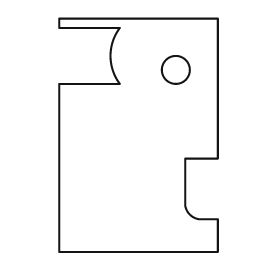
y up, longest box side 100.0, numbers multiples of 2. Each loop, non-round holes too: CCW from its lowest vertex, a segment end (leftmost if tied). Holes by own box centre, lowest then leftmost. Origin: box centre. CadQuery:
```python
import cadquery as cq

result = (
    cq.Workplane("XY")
    .moveTo(-34.0, -50.0)
    .lineTo(34.0, -50.0)
    .lineTo(34.0, -36.0)
    .lineTo(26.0, -36.0)
    .threePointArc((22.0, -34.0), (20.0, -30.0))
    .lineTo(20.0, -10.0)
    .lineTo(34.0, -10.0)
    .lineTo(34.0, 50.0)
    .lineTo(-34.0, 50.0)
    .lineTo(-34.0, 46.0)
    .lineTo(-8.0, 46.0)
    .threePointArc((-12.0, 34.0), (-8.0, 22.0))
    .lineTo(-34.0, 22.0)
    .close()
    .moveTo(16.0, 28.0)
    .circle(6.0)
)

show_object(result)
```